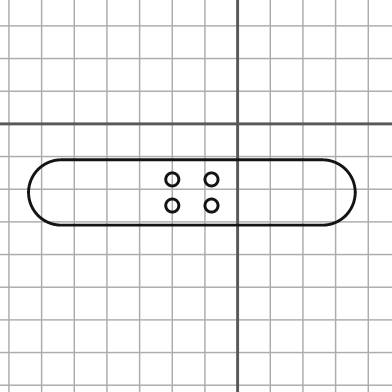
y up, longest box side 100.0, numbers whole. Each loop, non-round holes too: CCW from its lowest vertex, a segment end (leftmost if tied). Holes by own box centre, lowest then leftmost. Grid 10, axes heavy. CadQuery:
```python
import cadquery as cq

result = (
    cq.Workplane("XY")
    .moveTo(-54.0, -31.0)
    .lineTo(26.0, -31.0)
    .threePointArc((36.0, -21.0), (26.0, -11.0))
    .lineTo(-54.0, -11.0)
    .threePointArc((-64.0, -21.0), (-54.0, -31.0))
    .close()
    .moveTo(-20.0, -25.0)
    .circle(2.0)
    .moveTo(-8.0, -25.0)
    .circle(2.0)
    .moveTo(-20.0, -17.0)
    .circle(2.0)
    .moveTo(-8.0, -17.0)
    .circle(2.0)
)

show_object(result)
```